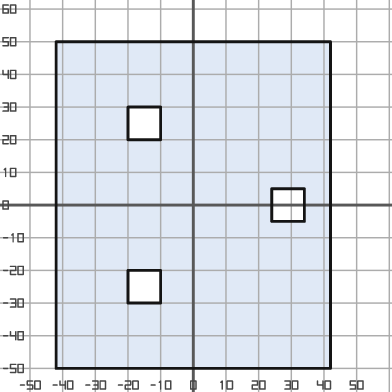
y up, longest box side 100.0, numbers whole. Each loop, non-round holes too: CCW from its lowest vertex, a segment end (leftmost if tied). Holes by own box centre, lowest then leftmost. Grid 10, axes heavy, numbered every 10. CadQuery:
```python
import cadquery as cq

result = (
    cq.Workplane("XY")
    .moveTo(-42.0, -50.0)
    .lineTo(42.0, -50.0)
    .lineTo(42.0, 50.0)
    .lineTo(-42.0, 50.0)
    .close()
    .moveTo(-20.0, -30.0)
    .lineTo(-10.0, -30.0)
    .lineTo(-10.0, -20.0)
    .lineTo(-20.0, -20.0)
    .close()
    .moveTo(24.0, -5.0)
    .lineTo(34.0, -5.0)
    .lineTo(34.0, 5.0)
    .lineTo(24.0, 5.0)
    .close()
    .moveTo(-20.0, 20.0)
    .lineTo(-10.0, 20.0)
    .lineTo(-10.0, 30.0)
    .lineTo(-20.0, 30.0)
    .close()
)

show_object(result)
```